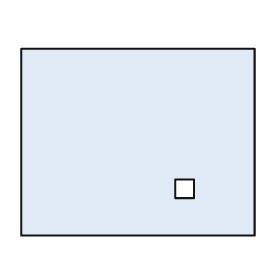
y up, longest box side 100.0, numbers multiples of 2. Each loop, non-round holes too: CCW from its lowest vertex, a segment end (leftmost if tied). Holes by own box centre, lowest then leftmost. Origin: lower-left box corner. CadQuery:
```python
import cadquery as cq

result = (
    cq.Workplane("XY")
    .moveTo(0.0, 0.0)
    .lineTo(100.0, 0.0)
    .lineTo(100.0, 80.0)
    .lineTo(0.0, 80.0)
    .close()
    .moveTo(66.0, 16.0)
    .lineTo(74.0, 16.0)
    .lineTo(74.0, 24.0)
    .lineTo(66.0, 24.0)
    .close()
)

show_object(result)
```